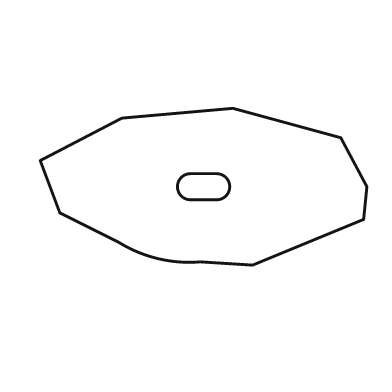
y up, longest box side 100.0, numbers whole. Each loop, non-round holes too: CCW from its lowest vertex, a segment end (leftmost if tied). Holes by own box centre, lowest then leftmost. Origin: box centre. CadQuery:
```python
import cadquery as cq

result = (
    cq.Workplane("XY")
    .moveTo(15.0, -24.0)
    .lineTo(49.0, -10.0)
    .lineTo(50.0, 0.0)
    .lineTo(42.0, 15.0)
    .lineTo(9.0, 24.0)
    .lineTo(-25.0, 21.0)
    .lineTo(-50.0, 8.0)
    .lineTo(-44.0, -8.0)
    .lineTo(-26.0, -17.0)
    .threePointArc((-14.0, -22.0), (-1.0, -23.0))
    .close()
    .moveTo(-4.0, -4.0)
    .lineTo(4.0, -4.0)
    .threePointArc((8.0, 0.0), (4.0, 4.0))
    .lineTo(-4.0, 4.0)
    .threePointArc((-8.0, 0.0), (-4.0, -4.0))
    .close()
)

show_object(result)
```